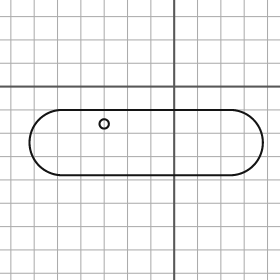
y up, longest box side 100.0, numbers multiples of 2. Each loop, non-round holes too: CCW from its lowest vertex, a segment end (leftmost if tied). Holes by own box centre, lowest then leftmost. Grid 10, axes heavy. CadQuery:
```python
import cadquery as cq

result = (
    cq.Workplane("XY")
    .moveTo(-48.0, -38.0)
    .lineTo(24.0, -38.0)
    .threePointArc((38.0, -24.0), (24.0, -10.0))
    .lineTo(-48.0, -10.0)
    .threePointArc((-62.0, -24.0), (-48.0, -38.0))
    .close()
    .moveTo(-30.0, -16.0)
    .circle(2.0)
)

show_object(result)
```